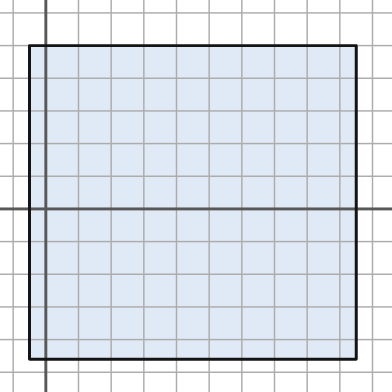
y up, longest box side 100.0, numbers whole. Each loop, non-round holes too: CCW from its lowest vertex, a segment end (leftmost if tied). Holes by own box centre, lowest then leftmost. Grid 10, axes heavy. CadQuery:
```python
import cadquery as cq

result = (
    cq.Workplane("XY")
    .moveTo(-5.0, -46.0)
    .lineTo(95.0, -46.0)
    .lineTo(95.0, 50.0)
    .lineTo(-5.0, 50.0)
    .close()
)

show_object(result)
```